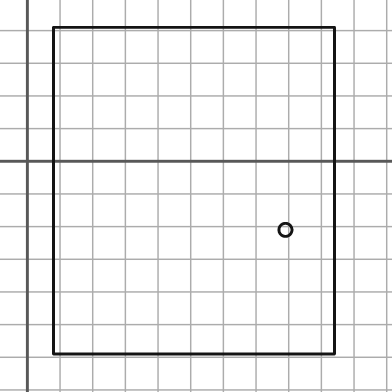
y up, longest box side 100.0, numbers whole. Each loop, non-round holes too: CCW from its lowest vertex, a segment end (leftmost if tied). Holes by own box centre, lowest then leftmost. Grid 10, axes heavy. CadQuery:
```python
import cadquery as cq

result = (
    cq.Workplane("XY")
    .moveTo(8.0, -59.0)
    .lineTo(94.0, -59.0)
    .lineTo(94.0, 41.0)
    .lineTo(8.0, 41.0)
    .close()
    .moveTo(79.0, -21.0)
    .circle(2.0)
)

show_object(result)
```